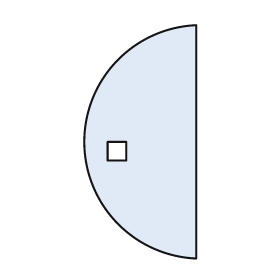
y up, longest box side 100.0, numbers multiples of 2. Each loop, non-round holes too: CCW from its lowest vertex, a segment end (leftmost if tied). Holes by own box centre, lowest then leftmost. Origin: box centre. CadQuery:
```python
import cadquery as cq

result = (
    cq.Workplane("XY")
    .moveTo(24.0, -50.0)
    .lineTo(24.0, 50.0)
    .threePointArc((-24.0, 0.0), (24.0, -50.0))
    .close()
    .moveTo(-14.0, -8.0)
    .lineTo(-6.0, -8.0)
    .lineTo(-6.0, 0.0)
    .lineTo(-14.0, 0.0)
    .close()
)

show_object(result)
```